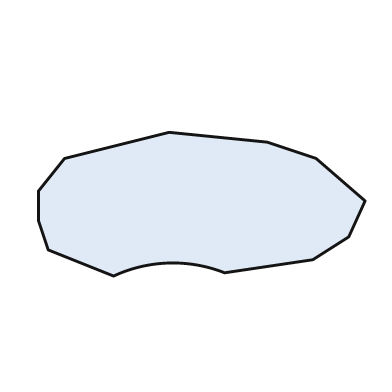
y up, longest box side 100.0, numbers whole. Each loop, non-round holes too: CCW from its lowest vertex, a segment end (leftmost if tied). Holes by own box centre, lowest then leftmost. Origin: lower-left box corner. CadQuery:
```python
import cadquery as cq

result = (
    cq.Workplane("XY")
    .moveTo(23.0, 0.0)
    .threePointArc((40.0, 4.0), (57.0, 1.0))
    .lineTo(84.0, 5.0)
    .lineTo(95.0, 12.0)
    .lineTo(100.0, 23.0)
    .lineTo(85.0, 36.0)
    .lineTo(70.0, 41.0)
    .lineTo(40.0, 44.0)
    .lineTo(8.0, 36.0)
    .lineTo(0.0, 26.0)
    .lineTo(0.0, 17.0)
    .lineTo(3.0, 8.0)
    .close()
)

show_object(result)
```